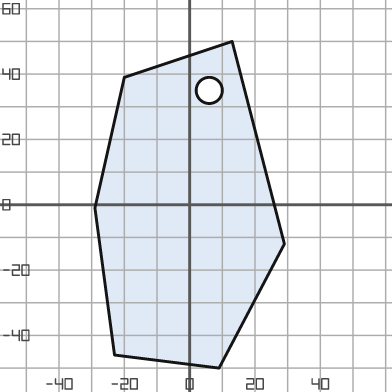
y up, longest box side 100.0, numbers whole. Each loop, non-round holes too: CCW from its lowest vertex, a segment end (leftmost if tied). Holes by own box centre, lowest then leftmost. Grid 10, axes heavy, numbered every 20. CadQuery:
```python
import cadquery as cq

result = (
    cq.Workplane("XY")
    .moveTo(9.0, -50.0)
    .lineTo(29.0, -12.0)
    .lineTo(13.0, 50.0)
    .lineTo(-20.0, 39.0)
    .lineTo(-29.0, -1.0)
    .lineTo(-23.0, -46.0)
    .close()
    .moveTo(6.0, 35.0)
    .circle(4.0)
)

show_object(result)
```